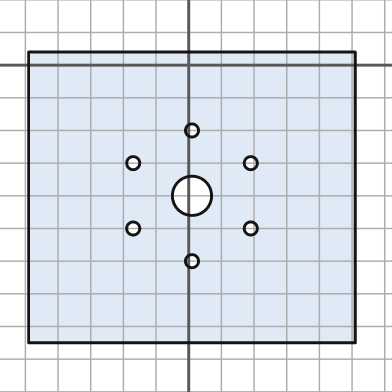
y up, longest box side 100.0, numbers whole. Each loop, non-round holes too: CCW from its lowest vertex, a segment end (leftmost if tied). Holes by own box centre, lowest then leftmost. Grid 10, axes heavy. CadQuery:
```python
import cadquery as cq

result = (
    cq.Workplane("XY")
    .moveTo(-49.0, -85.0)
    .lineTo(51.0, -85.0)
    .lineTo(51.0, 4.0)
    .lineTo(-49.0, 4.0)
    .close()
    .moveTo(1.0, -60.0)
    .circle(2.0)
    .moveTo(-17.0, -50.0)
    .circle(2.0)
    .moveTo(19.0, -50.0)
    .circle(2.0)
    .moveTo(1.0, -40.0)
    .circle(6.0)
    .moveTo(-17.0, -30.0)
    .circle(2.0)
    .moveTo(19.0, -30.0)
    .circle(2.0)
    .moveTo(1.0, -20.0)
    .circle(2.0)
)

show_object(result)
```